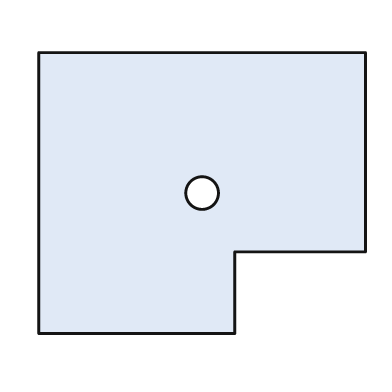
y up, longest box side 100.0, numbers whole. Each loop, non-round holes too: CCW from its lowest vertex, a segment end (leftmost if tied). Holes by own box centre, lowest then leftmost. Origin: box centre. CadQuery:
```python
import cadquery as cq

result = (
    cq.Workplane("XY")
    .moveTo(-50.0, -43.0)
    .lineTo(10.0, -43.0)
    .lineTo(10.0, -18.0)
    .lineTo(50.0, -18.0)
    .lineTo(50.0, 43.0)
    .lineTo(-50.0, 43.0)
    .close()
    .moveTo(0.0, 0.0)
    .circle(5.0)
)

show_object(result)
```